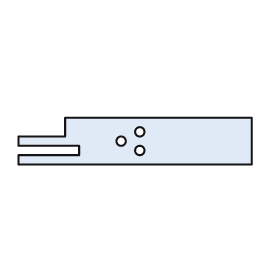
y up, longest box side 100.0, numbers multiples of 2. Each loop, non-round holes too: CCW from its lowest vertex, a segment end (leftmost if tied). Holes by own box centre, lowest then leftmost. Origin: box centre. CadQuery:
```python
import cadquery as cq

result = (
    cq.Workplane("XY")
    .moveTo(-50.0, -10.0)
    .lineTo(50.0, -10.0)
    .lineTo(50.0, 10.0)
    .lineTo(-30.0, 10.0)
    .lineTo(-30.0, 2.0)
    .lineTo(-50.0, 2.0)
    .lineTo(-50.0, -2.0)
    .lineTo(-24.0, -2.0)
    .lineTo(-24.0, -6.0)
    .lineTo(-50.0, -6.0)
    .close()
    .moveTo(2.0, -4.0)
    .circle(2.0)
    .moveTo(-6.0, 0.0)
    .circle(2.0)
    .moveTo(2.0, 4.0)
    .circle(2.0)
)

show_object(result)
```